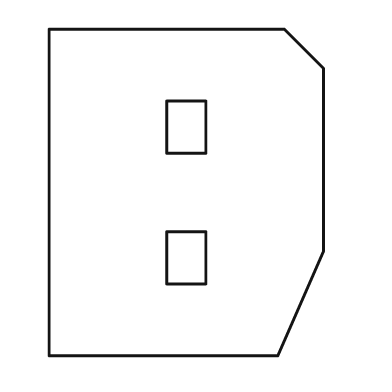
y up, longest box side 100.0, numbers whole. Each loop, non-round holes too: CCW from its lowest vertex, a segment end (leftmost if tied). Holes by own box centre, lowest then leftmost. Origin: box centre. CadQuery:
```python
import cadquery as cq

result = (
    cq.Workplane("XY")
    .moveTo(-42.0, -50.0)
    .lineTo(28.0, -50.0)
    .lineTo(42.0, -18.0)
    .lineTo(42.0, 38.0)
    .lineTo(30.0, 50.0)
    .lineTo(-42.0, 50.0)
    .close()
    .moveTo(-6.0, -28.0)
    .lineTo(6.0, -28.0)
    .lineTo(6.0, -12.0)
    .lineTo(-6.0, -12.0)
    .close()
    .moveTo(-6.0, 12.0)
    .lineTo(6.0, 12.0)
    .lineTo(6.0, 28.0)
    .lineTo(-6.0, 28.0)
    .close()
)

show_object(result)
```